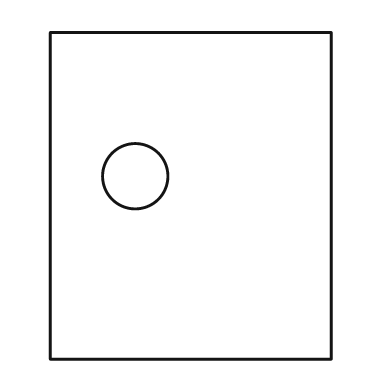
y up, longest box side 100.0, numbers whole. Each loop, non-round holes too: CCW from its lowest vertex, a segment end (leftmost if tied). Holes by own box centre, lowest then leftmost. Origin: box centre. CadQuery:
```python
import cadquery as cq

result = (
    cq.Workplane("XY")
    .moveTo(-43.0, -50.0)
    .lineTo(43.0, -50.0)
    .lineTo(43.0, 50.0)
    .lineTo(-43.0, 50.0)
    .close()
    .moveTo(-17.0, 6.0)
    .circle(10.0)
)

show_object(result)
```